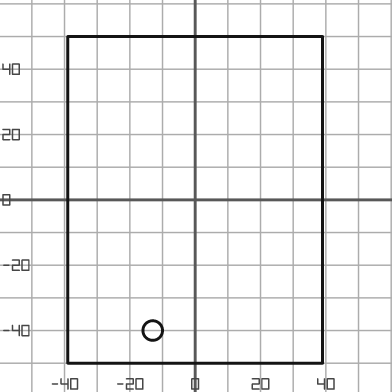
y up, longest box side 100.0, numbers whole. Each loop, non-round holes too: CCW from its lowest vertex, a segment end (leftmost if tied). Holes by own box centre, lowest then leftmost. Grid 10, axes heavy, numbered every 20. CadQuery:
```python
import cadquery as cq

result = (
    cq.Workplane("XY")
    .moveTo(-39.0, -50.0)
    .lineTo(39.0, -50.0)
    .lineTo(39.0, 50.0)
    .lineTo(-39.0, 50.0)
    .close()
    .moveTo(-13.0, -40.0)
    .circle(3.0)
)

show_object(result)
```